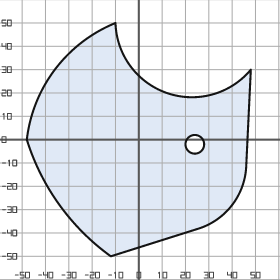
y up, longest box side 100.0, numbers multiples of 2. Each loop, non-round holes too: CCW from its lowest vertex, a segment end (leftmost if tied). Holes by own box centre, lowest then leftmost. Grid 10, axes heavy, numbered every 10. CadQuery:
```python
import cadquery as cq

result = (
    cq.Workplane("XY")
    .moveTo(-12.0, -50.0)
    .lineTo(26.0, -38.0)
    .threePointArc((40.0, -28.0), (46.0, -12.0))
    .lineTo(48.0, 30.0)
    .threePointArc((12.0, 20.0), (-10.0, 50.0))
    .threePointArc((-36.0, 30.0), (-48.0, 0.0))
    .threePointArc((-34.0, -28.0), (-12.0, -50.0))
    .close()
    .moveTo(24.0, -2.0)
    .circle(4.0)
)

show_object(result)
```